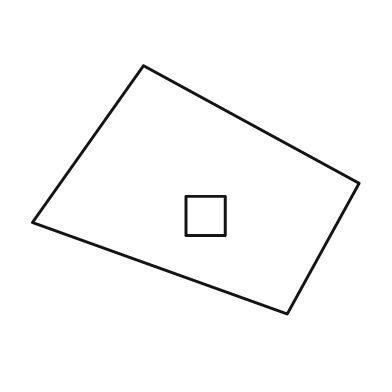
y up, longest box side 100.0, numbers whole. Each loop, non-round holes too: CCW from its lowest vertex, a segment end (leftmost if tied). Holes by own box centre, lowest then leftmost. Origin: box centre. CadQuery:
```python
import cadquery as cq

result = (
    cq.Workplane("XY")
    .moveTo(28.0, -38.0)
    .lineTo(50.0, 2.0)
    .lineTo(-16.0, 38.0)
    .lineTo(-50.0, -10.0)
    .close()
    .moveTo(-3.0, -14.0)
    .lineTo(9.0, -14.0)
    .lineTo(9.0, -2.0)
    .lineTo(-3.0, -2.0)
    .close()
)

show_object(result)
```